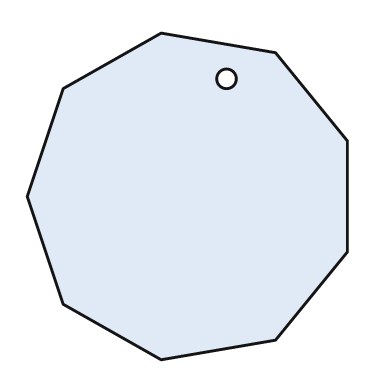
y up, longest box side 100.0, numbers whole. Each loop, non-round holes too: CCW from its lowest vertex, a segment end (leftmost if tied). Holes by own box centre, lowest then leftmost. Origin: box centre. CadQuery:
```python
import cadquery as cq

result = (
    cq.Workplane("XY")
    .moveTo(-8.0, -50.0)
    .lineTo(27.0, -44.0)
    .lineTo(49.0, -17.0)
    .lineTo(49.0, 17.0)
    .lineTo(27.0, 44.0)
    .lineTo(-8.0, 50.0)
    .lineTo(-38.0, 33.0)
    .lineTo(-49.0, 0.0)
    .lineTo(-38.0, -33.0)
    .close()
    .moveTo(12.0, 36.0)
    .circle(3.0)
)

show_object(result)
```